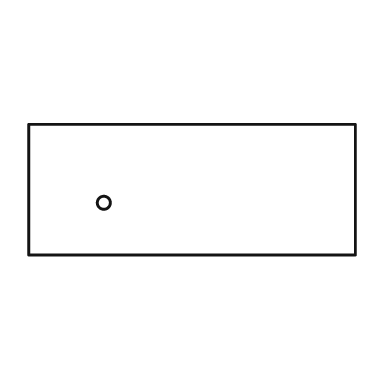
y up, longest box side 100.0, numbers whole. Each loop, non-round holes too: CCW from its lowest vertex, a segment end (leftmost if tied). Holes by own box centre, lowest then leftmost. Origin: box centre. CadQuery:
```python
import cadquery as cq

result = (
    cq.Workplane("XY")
    .moveTo(-50.0, -20.0)
    .lineTo(50.0, -20.0)
    .lineTo(50.0, 20.0)
    .lineTo(-50.0, 20.0)
    .close()
    .moveTo(-27.0, -4.0)
    .circle(2.0)
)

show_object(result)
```